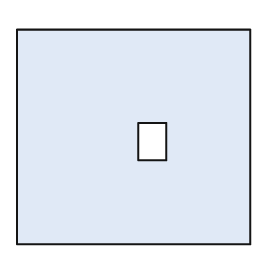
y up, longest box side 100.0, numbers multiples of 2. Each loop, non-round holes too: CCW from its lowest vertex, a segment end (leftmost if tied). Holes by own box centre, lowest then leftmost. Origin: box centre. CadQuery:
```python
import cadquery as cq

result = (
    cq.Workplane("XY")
    .moveTo(-50.0, -46.0)
    .lineTo(50.0, -46.0)
    .lineTo(50.0, 46.0)
    .lineTo(-50.0, 46.0)
    .close()
    .moveTo(2.0, -10.0)
    .lineTo(14.0, -10.0)
    .lineTo(14.0, 6.0)
    .lineTo(2.0, 6.0)
    .close()
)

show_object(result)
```